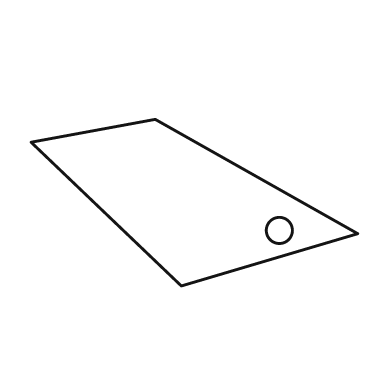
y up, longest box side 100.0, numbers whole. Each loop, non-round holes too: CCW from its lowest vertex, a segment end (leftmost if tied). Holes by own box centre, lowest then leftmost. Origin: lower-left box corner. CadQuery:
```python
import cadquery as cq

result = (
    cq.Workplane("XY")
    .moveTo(46.0, 0.0)
    .lineTo(100.0, 16.0)
    .lineTo(38.0, 51.0)
    .lineTo(0.0, 44.0)
    .close()
    .moveTo(76.0, 17.0)
    .circle(4.0)
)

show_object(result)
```